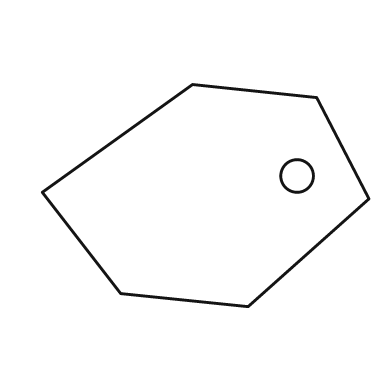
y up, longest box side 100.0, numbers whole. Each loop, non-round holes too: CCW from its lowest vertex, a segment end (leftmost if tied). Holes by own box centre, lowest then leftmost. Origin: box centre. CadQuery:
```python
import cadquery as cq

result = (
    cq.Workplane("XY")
    .moveTo(13.0, -34.0)
    .lineTo(50.0, -1.0)
    .lineTo(34.0, 30.0)
    .lineTo(-4.0, 34.0)
    .lineTo(-50.0, 1.0)
    .lineTo(-26.0, -30.0)
    .close()
    .moveTo(28.0, 6.0)
    .circle(5.0)
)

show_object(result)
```